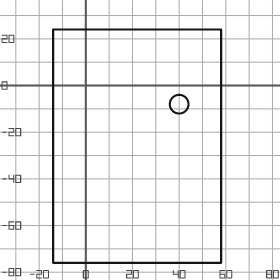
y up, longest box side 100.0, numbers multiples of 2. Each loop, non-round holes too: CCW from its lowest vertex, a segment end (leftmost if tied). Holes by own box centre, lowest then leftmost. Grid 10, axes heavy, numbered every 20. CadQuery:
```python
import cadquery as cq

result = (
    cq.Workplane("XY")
    .moveTo(-14.0, -76.0)
    .lineTo(58.0, -76.0)
    .lineTo(58.0, 24.0)
    .lineTo(-14.0, 24.0)
    .close()
    .moveTo(40.0, -8.0)
    .circle(4.0)
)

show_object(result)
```